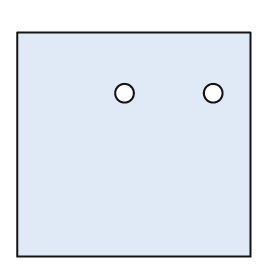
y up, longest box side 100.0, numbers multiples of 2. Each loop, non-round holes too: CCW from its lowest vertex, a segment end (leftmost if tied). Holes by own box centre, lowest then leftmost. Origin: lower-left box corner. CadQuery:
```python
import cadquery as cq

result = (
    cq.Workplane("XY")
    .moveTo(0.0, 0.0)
    .lineTo(100.0, 0.0)
    .lineTo(100.0, 96.0)
    .lineTo(0.0, 96.0)
    .close()
    .moveTo(46.0, 70.0)
    .circle(4.0)
    .moveTo(84.0, 70.0)
    .circle(4.0)
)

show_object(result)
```